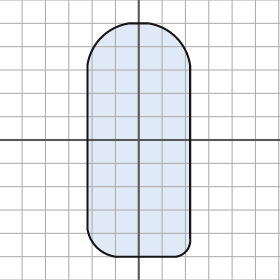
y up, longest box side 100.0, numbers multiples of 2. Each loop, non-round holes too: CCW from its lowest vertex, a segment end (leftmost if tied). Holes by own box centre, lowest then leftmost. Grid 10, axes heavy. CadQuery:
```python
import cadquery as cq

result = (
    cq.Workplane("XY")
    .moveTo(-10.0, -50.0)
    .lineTo(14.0, -50.0)
    .threePointArc((20.0, -48.0), (22.0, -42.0))
    .lineTo(22.0, 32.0)
    .threePointArc((16.0, 44.0), (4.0, 50.0))
    .lineTo(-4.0, 50.0)
    .threePointArc((-16.0, 44.0), (-22.0, 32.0))
    .lineTo(-22.0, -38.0)
    .threePointArc((-18.0, -46.0), (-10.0, -50.0))
    .close()
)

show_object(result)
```